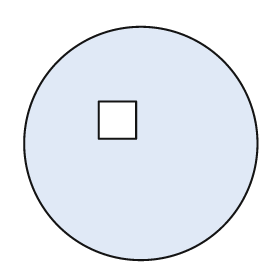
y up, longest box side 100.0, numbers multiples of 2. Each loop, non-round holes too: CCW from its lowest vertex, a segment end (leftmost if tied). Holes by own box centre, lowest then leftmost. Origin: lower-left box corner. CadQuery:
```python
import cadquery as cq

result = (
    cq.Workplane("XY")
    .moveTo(50.0, 50.0)
    .circle(50.0)
    .moveTo(32.0, 52.0)
    .lineTo(48.0, 52.0)
    .lineTo(48.0, 68.0)
    .lineTo(32.0, 68.0)
    .close()
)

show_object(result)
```